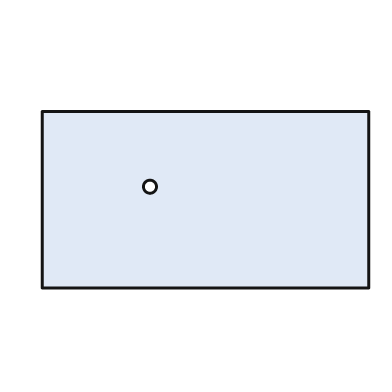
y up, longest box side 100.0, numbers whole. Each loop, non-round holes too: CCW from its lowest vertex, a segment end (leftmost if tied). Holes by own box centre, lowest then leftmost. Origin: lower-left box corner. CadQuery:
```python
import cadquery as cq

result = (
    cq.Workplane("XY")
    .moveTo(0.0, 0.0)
    .lineTo(100.0, 0.0)
    .lineTo(100.0, 54.0)
    .lineTo(0.0, 54.0)
    .close()
    .moveTo(33.0, 31.0)
    .circle(2.0)
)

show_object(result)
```